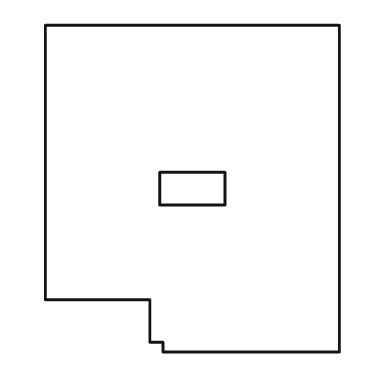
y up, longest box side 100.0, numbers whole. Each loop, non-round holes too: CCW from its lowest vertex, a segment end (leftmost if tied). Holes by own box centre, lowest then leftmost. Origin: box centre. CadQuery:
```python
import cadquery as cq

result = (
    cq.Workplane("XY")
    .moveTo(-9.0, -50.0)
    .lineTo(45.0, -50.0)
    .lineTo(45.0, 50.0)
    .lineTo(-45.0, 50.0)
    .lineTo(-45.0, -34.0)
    .lineTo(-13.0, -34.0)
    .lineTo(-13.0, -47.0)
    .lineTo(-9.0, -47.0)
    .close()
    .moveTo(-10.0, -5.0)
    .lineTo(10.0, -5.0)
    .lineTo(10.0, 5.0)
    .lineTo(-10.0, 5.0)
    .close()
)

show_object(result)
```